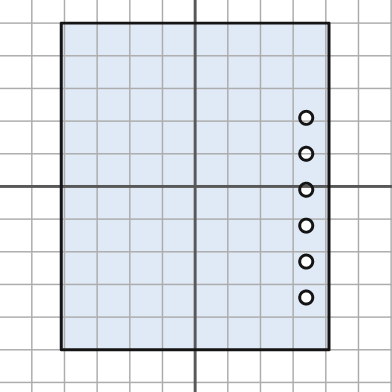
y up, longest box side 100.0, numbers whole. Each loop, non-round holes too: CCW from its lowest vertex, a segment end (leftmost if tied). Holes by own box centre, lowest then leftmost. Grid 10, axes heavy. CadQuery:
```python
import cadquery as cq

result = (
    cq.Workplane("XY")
    .moveTo(-41.0, -50.0)
    .lineTo(41.0, -50.0)
    .lineTo(41.0, 50.0)
    .lineTo(-41.0, 50.0)
    .close()
    .moveTo(34.0, -34.0)
    .circle(2.0)
    .moveTo(34.0, -23.0)
    .circle(2.0)
    .moveTo(34.0, -12.0)
    .circle(2.0)
    .moveTo(34.0, -1.0)
    .circle(2.0)
    .moveTo(34.0, 10.0)
    .circle(2.0)
    .moveTo(34.0, 21.0)
    .circle(2.0)
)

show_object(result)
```